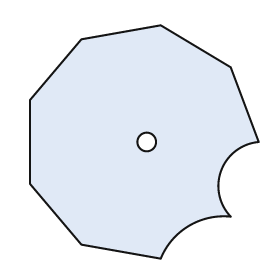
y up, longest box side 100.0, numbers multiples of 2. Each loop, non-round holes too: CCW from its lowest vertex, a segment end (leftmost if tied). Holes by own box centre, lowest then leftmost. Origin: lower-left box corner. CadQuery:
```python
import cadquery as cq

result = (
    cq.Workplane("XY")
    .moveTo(56.0, 0.0)
    .threePointArc((68.0, 14.0), (86.0, 18.0))
    .threePointArc((82.0, 38.0), (98.0, 50.0))
    .lineTo(86.0, 82.0)
    .lineTo(56.0, 100.0)
    .lineTo(22.0, 94.0)
    .lineTo(0.0, 68.0)
    .lineTo(0.0, 32.0)
    .lineTo(22.0, 6.0)
    .close()
    .moveTo(50.0, 50.0)
    .circle(4.0)
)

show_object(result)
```